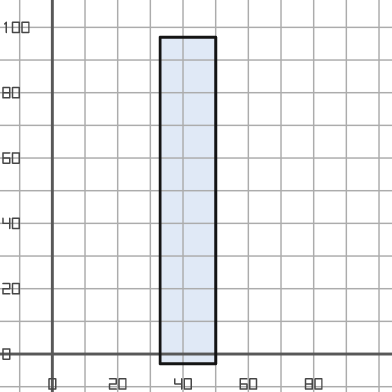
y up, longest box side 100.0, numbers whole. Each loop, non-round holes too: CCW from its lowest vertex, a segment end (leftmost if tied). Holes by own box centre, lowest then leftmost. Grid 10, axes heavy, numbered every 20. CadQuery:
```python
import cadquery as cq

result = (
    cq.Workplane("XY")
    .moveTo(33.0, -3.0)
    .lineTo(50.0, -3.0)
    .lineTo(50.0, 97.0)
    .lineTo(33.0, 97.0)
    .close()
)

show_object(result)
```